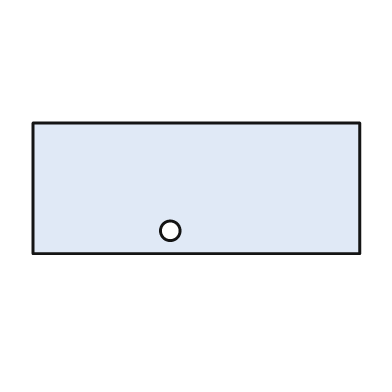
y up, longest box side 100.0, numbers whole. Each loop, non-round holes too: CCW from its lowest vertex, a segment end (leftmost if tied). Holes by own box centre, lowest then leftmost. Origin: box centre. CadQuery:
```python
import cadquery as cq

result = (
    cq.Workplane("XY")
    .moveTo(-50.0, -20.0)
    .lineTo(50.0, -20.0)
    .lineTo(50.0, 20.0)
    .lineTo(-50.0, 20.0)
    .close()
    .moveTo(-8.0, -13.0)
    .circle(3.0)
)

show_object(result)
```